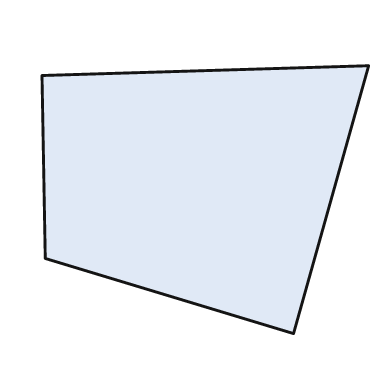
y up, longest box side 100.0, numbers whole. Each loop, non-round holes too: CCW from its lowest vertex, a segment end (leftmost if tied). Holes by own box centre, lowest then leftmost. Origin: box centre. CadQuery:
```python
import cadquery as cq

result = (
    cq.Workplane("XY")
    .moveTo(27.0, -41.0)
    .lineTo(50.0, 41.0)
    .lineTo(-50.0, 38.0)
    .lineTo(-49.0, -18.0)
    .close()
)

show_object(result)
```